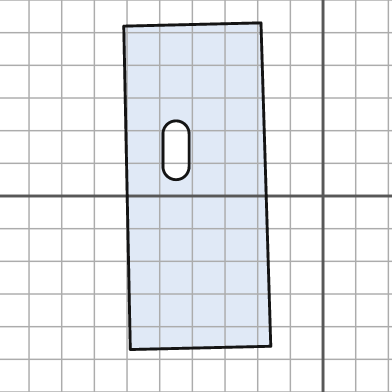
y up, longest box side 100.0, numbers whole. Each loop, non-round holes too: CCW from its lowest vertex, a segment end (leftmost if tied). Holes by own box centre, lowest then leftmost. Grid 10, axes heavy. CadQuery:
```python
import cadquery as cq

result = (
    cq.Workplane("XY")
    .moveTo(-59.0, -47.0)
    .lineTo(-16.0, -46.0)
    .lineTo(-19.0, 53.0)
    .lineTo(-61.0, 52.0)
    .close()
    .moveTo(-49.0, 9.0)
    .threePointArc((-45.0, 5.0), (-41.0, 9.0))
    .lineTo(-41.0, 19.0)
    .threePointArc((-45.0, 23.0), (-49.0, 19.0))
    .close()
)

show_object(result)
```